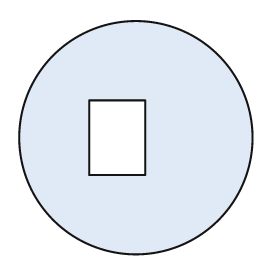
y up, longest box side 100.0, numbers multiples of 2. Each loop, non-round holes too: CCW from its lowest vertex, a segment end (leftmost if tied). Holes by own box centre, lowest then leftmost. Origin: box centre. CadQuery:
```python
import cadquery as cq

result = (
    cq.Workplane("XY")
    .moveTo(0.0, 0.0)
    .circle(50.0)
    .moveTo(-20.0, -16.0)
    .lineTo(4.0, -16.0)
    .lineTo(4.0, 16.0)
    .lineTo(-20.0, 16.0)
    .close()
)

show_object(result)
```